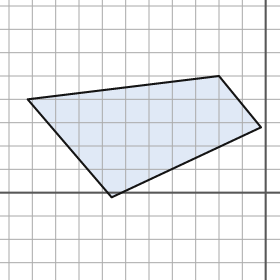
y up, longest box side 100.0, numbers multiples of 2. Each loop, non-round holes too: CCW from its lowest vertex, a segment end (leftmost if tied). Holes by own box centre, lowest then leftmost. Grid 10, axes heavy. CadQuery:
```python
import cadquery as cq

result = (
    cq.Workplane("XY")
    .moveTo(-66.0, -2.0)
    .lineTo(-2.0, 28.0)
    .lineTo(-20.0, 50.0)
    .lineTo(-102.0, 40.0)
    .close()
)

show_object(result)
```